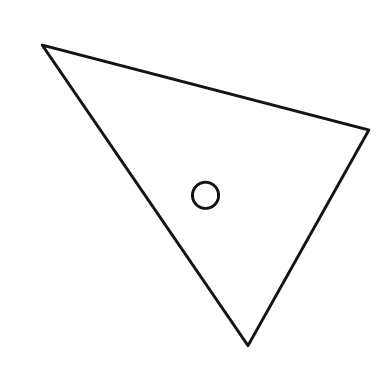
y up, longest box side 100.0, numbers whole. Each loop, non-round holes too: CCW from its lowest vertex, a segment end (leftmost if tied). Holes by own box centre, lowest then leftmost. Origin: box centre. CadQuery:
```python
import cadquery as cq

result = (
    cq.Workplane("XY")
    .moveTo(13.0, -46.0)
    .lineTo(50.0, 20.0)
    .lineTo(-50.0, 46.0)
    .close()
    .moveTo(0.0, 0.0)
    .circle(4.0)
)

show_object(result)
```